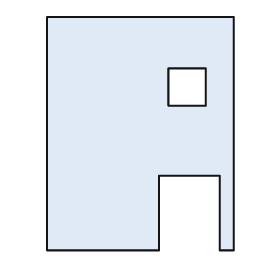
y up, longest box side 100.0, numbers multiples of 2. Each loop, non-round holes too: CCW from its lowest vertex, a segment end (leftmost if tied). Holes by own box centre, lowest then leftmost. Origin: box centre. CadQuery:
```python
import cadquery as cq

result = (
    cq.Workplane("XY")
    .moveTo(-40.0, -50.0)
    .lineTo(8.0, -50.0)
    .lineTo(8.0, -18.0)
    .lineTo(34.0, -18.0)
    .lineTo(34.0, -50.0)
    .lineTo(40.0, -50.0)
    .lineTo(40.0, 50.0)
    .lineTo(-40.0, 50.0)
    .close()
    .moveTo(12.0, 12.0)
    .lineTo(28.0, 12.0)
    .lineTo(28.0, 28.0)
    .lineTo(12.0, 28.0)
    .close()
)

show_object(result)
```